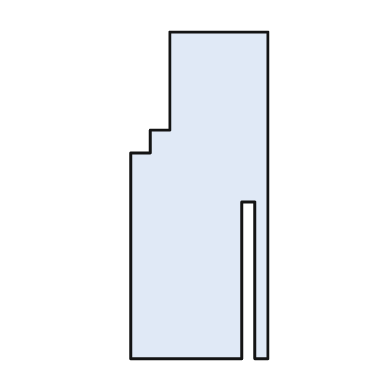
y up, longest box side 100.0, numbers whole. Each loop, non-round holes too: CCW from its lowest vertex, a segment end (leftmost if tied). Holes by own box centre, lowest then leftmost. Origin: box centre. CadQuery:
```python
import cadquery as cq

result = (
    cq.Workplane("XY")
    .moveTo(-21.0, -50.0)
    .lineTo(13.0, -50.0)
    .lineTo(13.0, -2.0)
    .lineTo(17.0, -2.0)
    .lineTo(17.0, -50.0)
    .lineTo(21.0, -50.0)
    .lineTo(21.0, 50.0)
    .lineTo(-9.0, 50.0)
    .lineTo(-9.0, 20.0)
    .lineTo(-15.0, 20.0)
    .lineTo(-15.0, 13.0)
    .lineTo(-21.0, 13.0)
    .close()
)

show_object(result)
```